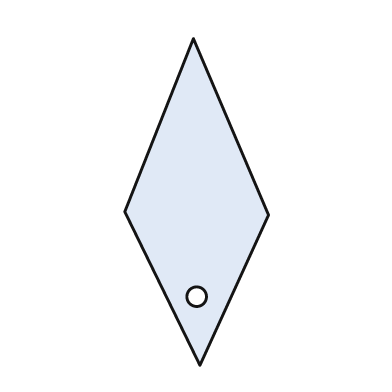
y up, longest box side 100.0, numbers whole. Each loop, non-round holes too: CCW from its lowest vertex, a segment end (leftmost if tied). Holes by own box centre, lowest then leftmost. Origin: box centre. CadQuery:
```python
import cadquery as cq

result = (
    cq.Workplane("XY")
    .moveTo(1.0, -50.0)
    .lineTo(22.0, -4.0)
    .lineTo(-1.0, 50.0)
    .lineTo(-22.0, -3.0)
    .close()
    .moveTo(0.0, -29.0)
    .circle(3.0)
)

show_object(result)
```